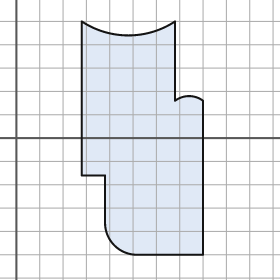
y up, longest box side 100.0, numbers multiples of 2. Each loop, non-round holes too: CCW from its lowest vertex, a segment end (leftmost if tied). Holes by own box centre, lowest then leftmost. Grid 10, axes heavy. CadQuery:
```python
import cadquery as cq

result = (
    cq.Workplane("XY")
    .moveTo(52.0, -50.0)
    .lineTo(80.0, -50.0)
    .lineTo(80.0, 16.0)
    .threePointArc((74.0, 18.0), (68.0, 16.0))
    .lineTo(68.0, 50.0)
    .threePointArc((48.0, 44.0), (28.0, 50.0))
    .lineTo(28.0, -16.0)
    .lineTo(38.0, -16.0)
    .lineTo(38.0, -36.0)
    .threePointArc((42.0, -46.0), (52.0, -50.0))
    .close()
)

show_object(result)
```